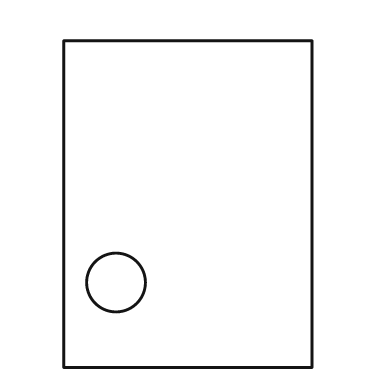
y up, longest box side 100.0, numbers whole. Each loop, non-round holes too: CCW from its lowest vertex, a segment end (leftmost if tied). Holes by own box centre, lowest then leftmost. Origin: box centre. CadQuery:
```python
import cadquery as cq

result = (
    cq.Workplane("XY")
    .moveTo(-38.0, -50.0)
    .lineTo(38.0, -50.0)
    .lineTo(38.0, 50.0)
    .lineTo(-38.0, 50.0)
    .close()
    .moveTo(-22.0, -24.0)
    .circle(9.0)
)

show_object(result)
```